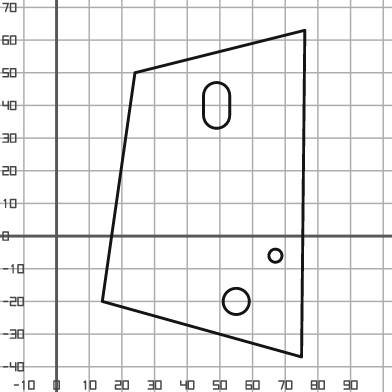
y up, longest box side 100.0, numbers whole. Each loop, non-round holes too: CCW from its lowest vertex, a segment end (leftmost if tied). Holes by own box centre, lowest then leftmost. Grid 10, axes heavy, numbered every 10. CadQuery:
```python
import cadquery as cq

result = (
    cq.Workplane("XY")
    .moveTo(75.0, -37.0)
    .lineTo(76.0, 63.0)
    .lineTo(24.0, 50.0)
    .lineTo(14.0, -20.0)
    .close()
    .moveTo(55.0, -20.0)
    .circle(4.0)
    .moveTo(67.0, -6.0)
    .circle(2.0)
    .moveTo(45.0, 37.0)
    .threePointArc((49.0, 33.0), (53.0, 37.0))
    .lineTo(53.0, 43.0)
    .threePointArc((49.0, 47.0), (45.0, 43.0))
    .close()
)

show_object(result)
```